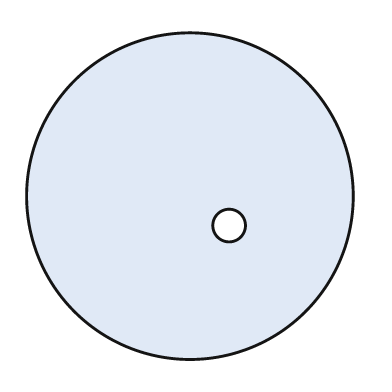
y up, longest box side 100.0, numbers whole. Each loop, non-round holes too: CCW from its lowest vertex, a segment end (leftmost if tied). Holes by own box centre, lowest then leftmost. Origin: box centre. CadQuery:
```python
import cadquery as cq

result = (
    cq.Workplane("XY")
    .moveTo(0.0, 0.0)
    .circle(50.0)
    .moveTo(12.0, -9.0)
    .circle(5.0)
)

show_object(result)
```